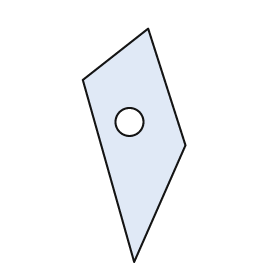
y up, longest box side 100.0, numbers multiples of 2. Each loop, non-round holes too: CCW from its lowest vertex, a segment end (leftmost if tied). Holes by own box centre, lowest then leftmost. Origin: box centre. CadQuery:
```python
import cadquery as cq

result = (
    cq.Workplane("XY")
    .moveTo(0.0, -50.0)
    .lineTo(22.0, 0.0)
    .lineTo(6.0, 50.0)
    .lineTo(-22.0, 28.0)
    .close()
    .moveTo(-2.0, 10.0)
    .circle(6.0)
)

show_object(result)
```